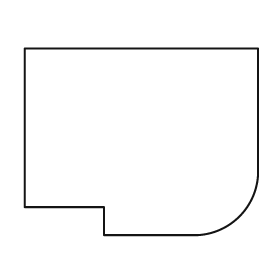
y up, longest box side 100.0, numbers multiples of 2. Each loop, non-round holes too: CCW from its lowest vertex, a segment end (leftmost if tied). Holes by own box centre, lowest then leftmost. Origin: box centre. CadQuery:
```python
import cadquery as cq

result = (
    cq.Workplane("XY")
    .moveTo(-16.0, -40.0)
    .lineTo(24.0, -40.0)
    .threePointArc((42.0, -32.0), (50.0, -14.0))
    .lineTo(50.0, 40.0)
    .lineTo(-50.0, 40.0)
    .lineTo(-50.0, -28.0)
    .lineTo(-16.0, -28.0)
    .close()
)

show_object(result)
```